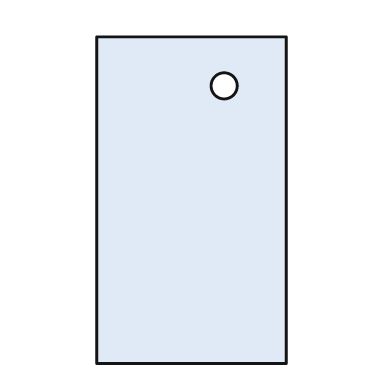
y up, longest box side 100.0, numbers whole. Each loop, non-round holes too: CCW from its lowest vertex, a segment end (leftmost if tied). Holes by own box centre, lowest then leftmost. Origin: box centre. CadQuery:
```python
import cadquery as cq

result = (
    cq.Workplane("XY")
    .moveTo(-29.0, -50.0)
    .lineTo(29.0, -50.0)
    .lineTo(29.0, 50.0)
    .lineTo(-29.0, 50.0)
    .close()
    .moveTo(10.0, 35.0)
    .circle(4.0)
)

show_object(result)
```